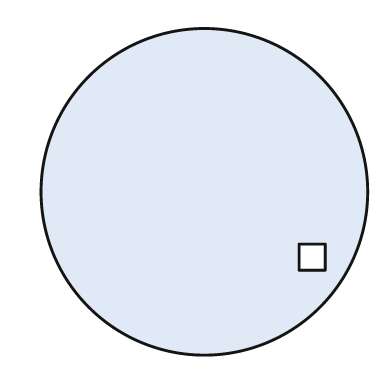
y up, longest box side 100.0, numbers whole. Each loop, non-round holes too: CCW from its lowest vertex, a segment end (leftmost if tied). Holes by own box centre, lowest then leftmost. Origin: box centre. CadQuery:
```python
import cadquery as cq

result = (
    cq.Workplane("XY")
    .moveTo(0.0, 0.0)
    .circle(50.0)
    .moveTo(29.0, -24.0)
    .lineTo(37.0, -24.0)
    .lineTo(37.0, -16.0)
    .lineTo(29.0, -16.0)
    .close()
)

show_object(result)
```